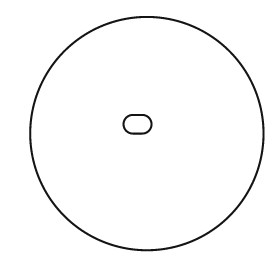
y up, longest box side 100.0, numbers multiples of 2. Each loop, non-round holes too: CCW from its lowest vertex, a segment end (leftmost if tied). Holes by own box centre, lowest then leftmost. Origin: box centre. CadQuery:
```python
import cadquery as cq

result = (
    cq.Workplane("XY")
    .moveTo(0.0, 0.0)
    .circle(50.0)
    .moveTo(-6.0, 0.0)
    .lineTo(-2.0, 0.0)
    .threePointArc((2.0, 4.0), (-2.0, 8.0))
    .lineTo(-6.0, 8.0)
    .threePointArc((-10.0, 4.0), (-6.0, 0.0))
    .close()
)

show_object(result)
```